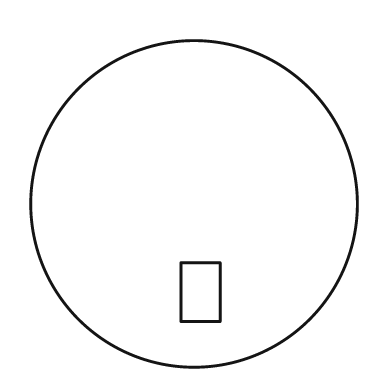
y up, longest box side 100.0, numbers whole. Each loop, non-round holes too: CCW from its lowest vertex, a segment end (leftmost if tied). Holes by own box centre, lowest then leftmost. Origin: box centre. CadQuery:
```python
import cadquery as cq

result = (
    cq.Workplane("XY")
    .moveTo(0.0, 0.0)
    .circle(50.0)
    .moveTo(-4.0, -36.0)
    .lineTo(8.0, -36.0)
    .lineTo(8.0, -18.0)
    .lineTo(-4.0, -18.0)
    .close()
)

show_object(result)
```